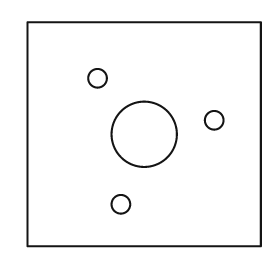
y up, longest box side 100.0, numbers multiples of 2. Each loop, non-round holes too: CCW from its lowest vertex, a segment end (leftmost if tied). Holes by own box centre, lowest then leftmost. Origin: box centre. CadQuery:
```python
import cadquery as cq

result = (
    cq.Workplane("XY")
    .moveTo(-50.0, -48.0)
    .lineTo(50.0, -48.0)
    .lineTo(50.0, 48.0)
    .lineTo(-50.0, 48.0)
    .close()
    .moveTo(-10.0, -30.0)
    .circle(4.0)
    .moveTo(0.0, 0.0)
    .circle(14.0)
    .moveTo(30.0, 6.0)
    .circle(4.0)
    .moveTo(-20.0, 24.0)
    .circle(4.0)
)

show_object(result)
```